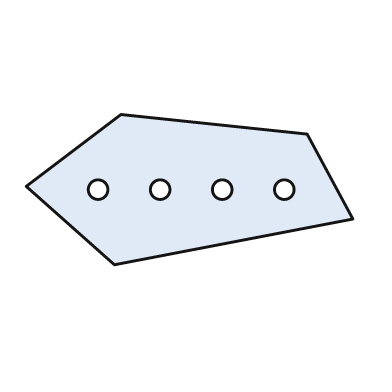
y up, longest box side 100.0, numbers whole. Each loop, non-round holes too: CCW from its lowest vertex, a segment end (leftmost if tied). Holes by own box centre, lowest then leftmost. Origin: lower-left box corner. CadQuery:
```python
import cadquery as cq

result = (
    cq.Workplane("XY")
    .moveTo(27.0, 0.0)
    .lineTo(100.0, 14.0)
    .lineTo(86.0, 40.0)
    .lineTo(29.0, 46.0)
    .lineTo(0.0, 24.0)
    .close()
    .moveTo(22.0, 23.0)
    .circle(3.0)
    .moveTo(41.0, 23.0)
    .circle(3.0)
    .moveTo(60.0, 23.0)
    .circle(3.0)
    .moveTo(79.0, 23.0)
    .circle(3.0)
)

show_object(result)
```